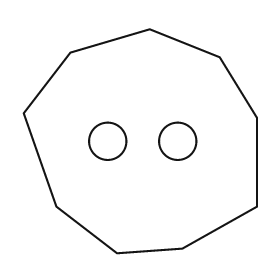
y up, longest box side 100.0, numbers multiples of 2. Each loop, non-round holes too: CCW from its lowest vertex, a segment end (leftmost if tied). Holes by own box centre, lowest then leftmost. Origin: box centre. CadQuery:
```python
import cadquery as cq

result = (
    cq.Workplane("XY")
    .moveTo(-10.0, -48.0)
    .lineTo(18.0, -46.0)
    .lineTo(50.0, -28.0)
    .lineTo(50.0, 10.0)
    .lineTo(34.0, 36.0)
    .lineTo(4.0, 48.0)
    .lineTo(-30.0, 38.0)
    .lineTo(-50.0, 12.0)
    .lineTo(-36.0, -28.0)
    .close()
    .moveTo(-14.0, 0.0)
    .circle(8.0)
    .moveTo(16.0, 0.0)
    .circle(8.0)
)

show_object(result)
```